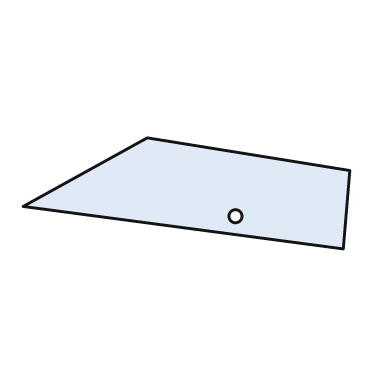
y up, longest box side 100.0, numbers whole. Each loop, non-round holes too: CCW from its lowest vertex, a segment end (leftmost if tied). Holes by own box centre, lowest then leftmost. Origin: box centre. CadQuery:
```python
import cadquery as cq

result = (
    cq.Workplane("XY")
    .moveTo(48.0, -17.0)
    .lineTo(50.0, 7.0)
    .lineTo(-12.0, 17.0)
    .lineTo(-50.0, -4.0)
    .close()
    .moveTo(15.0, -7.0)
    .circle(2.0)
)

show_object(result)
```